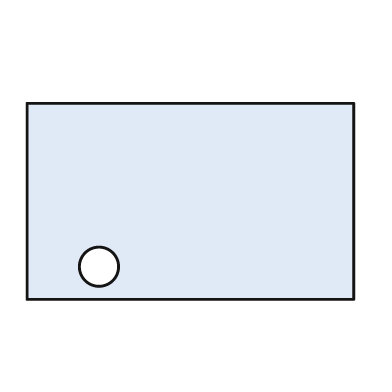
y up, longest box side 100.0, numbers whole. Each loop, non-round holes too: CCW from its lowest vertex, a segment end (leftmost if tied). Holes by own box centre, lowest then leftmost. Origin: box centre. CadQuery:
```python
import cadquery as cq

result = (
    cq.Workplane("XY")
    .moveTo(-50.0, -30.0)
    .lineTo(50.0, -30.0)
    .lineTo(50.0, 30.0)
    .lineTo(-50.0, 30.0)
    .close()
    .moveTo(-28.0, -20.0)
    .circle(6.0)
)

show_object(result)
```